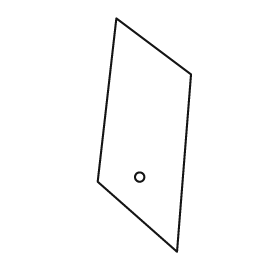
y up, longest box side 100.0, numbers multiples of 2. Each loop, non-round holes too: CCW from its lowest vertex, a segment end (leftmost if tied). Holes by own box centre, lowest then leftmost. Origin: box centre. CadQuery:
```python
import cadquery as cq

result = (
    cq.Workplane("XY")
    .moveTo(14.0, -50.0)
    .lineTo(20.0, 26.0)
    .lineTo(-12.0, 50.0)
    .lineTo(-20.0, -20.0)
    .close()
    .moveTo(-2.0, -18.0)
    .circle(2.0)
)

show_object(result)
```